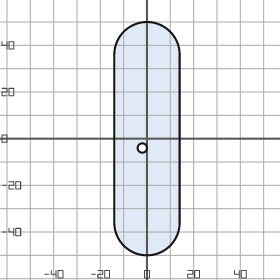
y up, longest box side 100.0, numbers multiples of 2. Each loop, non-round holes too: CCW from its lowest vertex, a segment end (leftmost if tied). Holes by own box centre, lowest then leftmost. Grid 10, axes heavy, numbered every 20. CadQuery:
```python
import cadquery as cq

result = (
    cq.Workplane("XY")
    .moveTo(-14.0, -36.0)
    .threePointArc((0.0, -50.0), (14.0, -36.0))
    .lineTo(14.0, 36.0)
    .threePointArc((0.0, 50.0), (-14.0, 36.0))
    .close()
    .moveTo(-2.0, -4.0)
    .circle(2.0)
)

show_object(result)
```